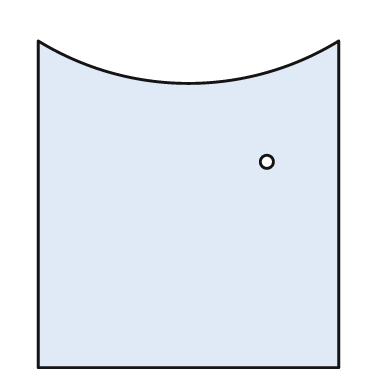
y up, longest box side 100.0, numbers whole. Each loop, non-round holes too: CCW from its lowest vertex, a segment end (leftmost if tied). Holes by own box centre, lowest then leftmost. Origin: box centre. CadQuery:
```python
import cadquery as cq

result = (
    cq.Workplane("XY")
    .moveTo(-46.0, -50.0)
    .lineTo(46.0, -50.0)
    .lineTo(46.0, 50.0)
    .threePointArc((0.0, 37.0), (-46.0, 50.0))
    .close()
    .moveTo(24.0, 13.0)
    .circle(2.0)
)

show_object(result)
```